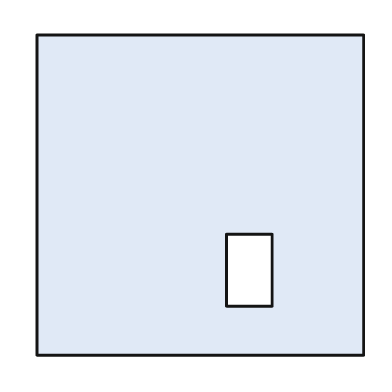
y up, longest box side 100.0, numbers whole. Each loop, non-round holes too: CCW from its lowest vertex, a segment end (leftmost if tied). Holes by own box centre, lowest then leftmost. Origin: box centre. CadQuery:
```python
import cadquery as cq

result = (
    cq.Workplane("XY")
    .moveTo(-50.0, -49.0)
    .lineTo(50.0, -49.0)
    .lineTo(50.0, 49.0)
    .lineTo(-50.0, 49.0)
    .close()
    .moveTo(8.0, -34.0)
    .lineTo(22.0, -34.0)
    .lineTo(22.0, -12.0)
    .lineTo(8.0, -12.0)
    .close()
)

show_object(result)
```